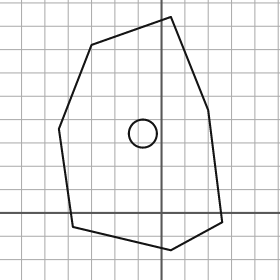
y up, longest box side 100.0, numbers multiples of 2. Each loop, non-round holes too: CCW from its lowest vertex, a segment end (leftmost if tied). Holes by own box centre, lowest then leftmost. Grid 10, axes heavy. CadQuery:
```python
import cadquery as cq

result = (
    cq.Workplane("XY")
    .moveTo(4.0, -16.0)
    .lineTo(26.0, -4.0)
    .lineTo(20.0, 44.0)
    .lineTo(4.0, 84.0)
    .lineTo(-30.0, 72.0)
    .lineTo(-44.0, 36.0)
    .lineTo(-38.0, -6.0)
    .close()
    .moveTo(-8.0, 34.0)
    .circle(6.0)
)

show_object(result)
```